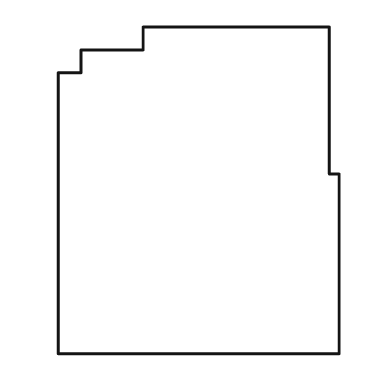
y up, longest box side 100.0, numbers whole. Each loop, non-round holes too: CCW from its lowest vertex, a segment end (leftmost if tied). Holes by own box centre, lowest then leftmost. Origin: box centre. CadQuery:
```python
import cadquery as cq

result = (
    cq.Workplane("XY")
    .moveTo(-43.0, -50.0)
    .lineTo(43.0, -50.0)
    .lineTo(43.0, 5.0)
    .lineTo(40.0, 5.0)
    .lineTo(40.0, 50.0)
    .lineTo(-17.0, 50.0)
    .lineTo(-17.0, 43.0)
    .lineTo(-36.0, 43.0)
    .lineTo(-36.0, 36.0)
    .lineTo(-43.0, 36.0)
    .close()
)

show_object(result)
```